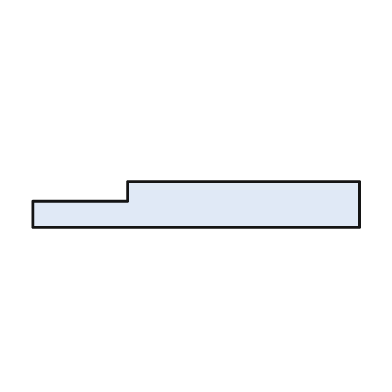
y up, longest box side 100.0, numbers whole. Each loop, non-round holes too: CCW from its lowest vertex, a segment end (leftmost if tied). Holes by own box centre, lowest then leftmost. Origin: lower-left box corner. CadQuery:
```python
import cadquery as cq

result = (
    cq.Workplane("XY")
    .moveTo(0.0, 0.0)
    .lineTo(100.0, 0.0)
    .lineTo(100.0, 14.0)
    .lineTo(29.0, 14.0)
    .lineTo(29.0, 8.0)
    .lineTo(0.0, 8.0)
    .close()
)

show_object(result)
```